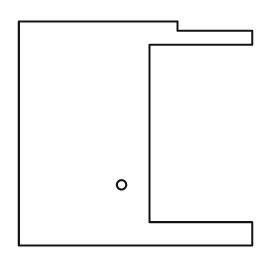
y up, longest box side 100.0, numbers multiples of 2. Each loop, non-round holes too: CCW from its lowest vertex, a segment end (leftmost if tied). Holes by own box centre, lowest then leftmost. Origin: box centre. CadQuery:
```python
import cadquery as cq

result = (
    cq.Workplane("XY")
    .moveTo(-50.0, -48.0)
    .lineTo(50.0, -48.0)
    .lineTo(50.0, -38.0)
    .lineTo(6.0, -38.0)
    .lineTo(6.0, 38.0)
    .lineTo(50.0, 38.0)
    .lineTo(50.0, 44.0)
    .lineTo(18.0, 44.0)
    .lineTo(18.0, 48.0)
    .lineTo(-50.0, 48.0)
    .close()
    .moveTo(-6.0, -22.0)
    .circle(2.0)
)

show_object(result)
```